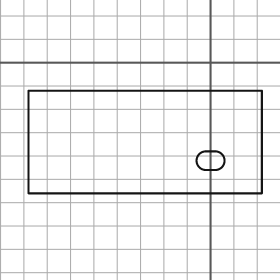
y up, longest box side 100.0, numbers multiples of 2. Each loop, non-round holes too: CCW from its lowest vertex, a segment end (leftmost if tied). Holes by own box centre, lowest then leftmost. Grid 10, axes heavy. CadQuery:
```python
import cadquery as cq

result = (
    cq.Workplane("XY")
    .moveTo(-78.0, -56.0)
    .lineTo(22.0, -56.0)
    .lineTo(22.0, -12.0)
    .lineTo(-78.0, -12.0)
    .close()
    .moveTo(-2.0, -46.0)
    .lineTo(2.0, -46.0)
    .threePointArc((6.0, -42.0), (2.0, -38.0))
    .lineTo(-2.0, -38.0)
    .threePointArc((-6.0, -42.0), (-2.0, -46.0))
    .close()
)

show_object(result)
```